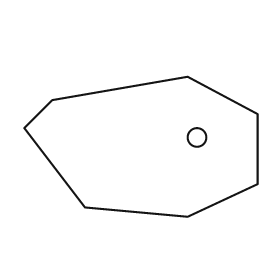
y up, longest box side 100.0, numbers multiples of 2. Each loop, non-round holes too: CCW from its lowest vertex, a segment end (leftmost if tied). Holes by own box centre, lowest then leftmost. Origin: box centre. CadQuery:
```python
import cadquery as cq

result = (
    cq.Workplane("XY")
    .moveTo(20.0, -30.0)
    .lineTo(50.0, -16.0)
    .lineTo(50.0, 14.0)
    .lineTo(20.0, 30.0)
    .lineTo(-38.0, 20.0)
    .lineTo(-50.0, 8.0)
    .lineTo(-24.0, -26.0)
    .close()
    .moveTo(24.0, 4.0)
    .circle(4.0)
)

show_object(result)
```